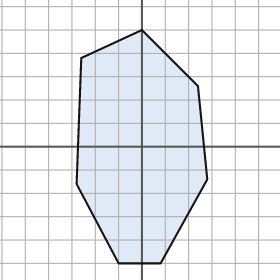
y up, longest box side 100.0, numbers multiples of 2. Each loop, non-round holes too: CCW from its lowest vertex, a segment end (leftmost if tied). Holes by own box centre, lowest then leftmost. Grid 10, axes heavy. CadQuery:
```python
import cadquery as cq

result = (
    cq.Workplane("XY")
    .moveTo(-10.0, -50.0)
    .lineTo(8.0, -50.0)
    .lineTo(28.0, -14.0)
    .lineTo(24.0, 26.0)
    .lineTo(0.0, 50.0)
    .lineTo(-26.0, 38.0)
    .lineTo(-28.0, -16.0)
    .close()
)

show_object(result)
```